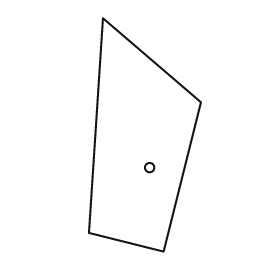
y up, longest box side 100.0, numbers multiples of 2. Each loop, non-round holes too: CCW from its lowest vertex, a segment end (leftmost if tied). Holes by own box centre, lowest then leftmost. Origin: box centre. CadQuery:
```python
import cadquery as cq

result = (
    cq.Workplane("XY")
    .moveTo(8.0, -50.0)
    .lineTo(24.0, 14.0)
    .lineTo(-18.0, 50.0)
    .lineTo(-24.0, -42.0)
    .close()
    .moveTo(2.0, -14.0)
    .circle(2.0)
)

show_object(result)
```